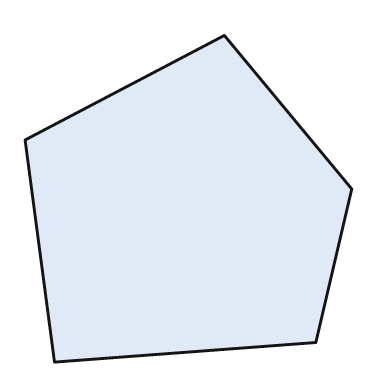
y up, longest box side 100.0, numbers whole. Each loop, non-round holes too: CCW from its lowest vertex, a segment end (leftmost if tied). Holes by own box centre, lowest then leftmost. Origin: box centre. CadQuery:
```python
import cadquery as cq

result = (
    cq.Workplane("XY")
    .moveTo(-41.0, -50.0)
    .lineTo(39.0, -44.0)
    .lineTo(50.0, 3.0)
    .lineTo(11.0, 50.0)
    .lineTo(-50.0, 18.0)
    .close()
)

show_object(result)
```